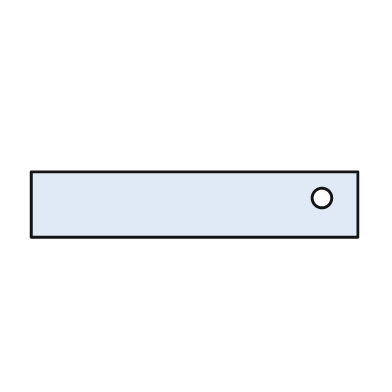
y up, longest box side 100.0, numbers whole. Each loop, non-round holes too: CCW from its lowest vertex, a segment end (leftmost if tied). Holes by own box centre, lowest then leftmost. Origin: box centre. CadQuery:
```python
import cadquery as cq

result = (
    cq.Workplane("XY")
    .moveTo(-50.0, -10.0)
    .lineTo(50.0, -10.0)
    .lineTo(50.0, 10.0)
    .lineTo(-50.0, 10.0)
    .close()
    .moveTo(39.0, 2.0)
    .circle(3.0)
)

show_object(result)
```